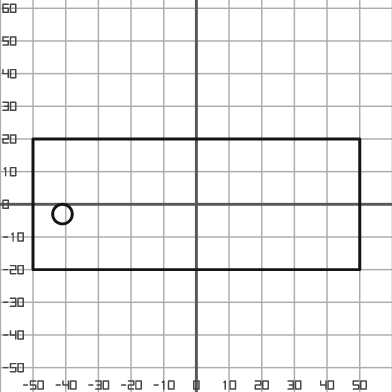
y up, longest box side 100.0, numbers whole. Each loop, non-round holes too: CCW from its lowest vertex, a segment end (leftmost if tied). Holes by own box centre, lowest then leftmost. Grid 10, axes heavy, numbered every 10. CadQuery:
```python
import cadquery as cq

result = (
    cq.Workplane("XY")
    .moveTo(-50.0, -20.0)
    .lineTo(50.0, -20.0)
    .lineTo(50.0, 20.0)
    .lineTo(-50.0, 20.0)
    .close()
    .moveTo(-41.0, -3.0)
    .circle(3.0)
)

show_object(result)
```